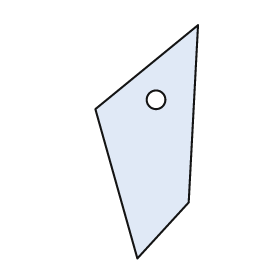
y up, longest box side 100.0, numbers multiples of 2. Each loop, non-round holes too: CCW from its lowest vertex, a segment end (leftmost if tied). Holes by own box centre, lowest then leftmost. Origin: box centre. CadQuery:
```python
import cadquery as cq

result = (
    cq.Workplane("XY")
    .moveTo(-4.0, -50.0)
    .lineTo(18.0, -26.0)
    .lineTo(22.0, 50.0)
    .lineTo(-22.0, 14.0)
    .close()
    .moveTo(4.0, 18.0)
    .circle(4.0)
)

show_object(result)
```